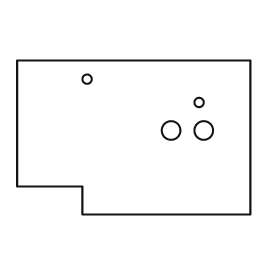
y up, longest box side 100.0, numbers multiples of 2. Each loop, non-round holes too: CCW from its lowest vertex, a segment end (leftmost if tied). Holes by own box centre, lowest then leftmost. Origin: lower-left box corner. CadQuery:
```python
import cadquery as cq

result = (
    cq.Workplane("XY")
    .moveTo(28.0, 0.0)
    .lineTo(100.0, 0.0)
    .lineTo(100.0, 66.0)
    .lineTo(0.0, 66.0)
    .lineTo(0.0, 12.0)
    .lineTo(28.0, 12.0)
    .close()
    .moveTo(66.0, 36.0)
    .circle(4.0)
    .moveTo(80.0, 36.0)
    .circle(4.0)
    .moveTo(78.0, 48.0)
    .circle(2.0)
    .moveTo(30.0, 58.0)
    .circle(2.0)
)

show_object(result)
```